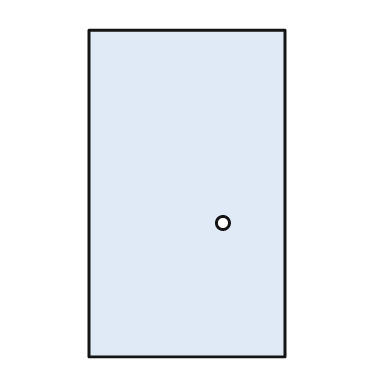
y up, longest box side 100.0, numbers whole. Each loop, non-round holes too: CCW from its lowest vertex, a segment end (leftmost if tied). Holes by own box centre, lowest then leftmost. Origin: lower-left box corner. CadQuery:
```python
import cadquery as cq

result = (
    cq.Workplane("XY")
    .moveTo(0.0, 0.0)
    .lineTo(60.0, 0.0)
    .lineTo(60.0, 100.0)
    .lineTo(0.0, 100.0)
    .close()
    .moveTo(41.0, 41.0)
    .circle(2.0)
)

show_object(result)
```